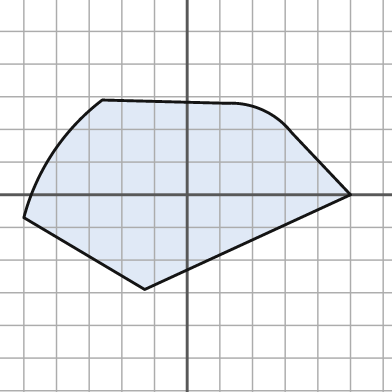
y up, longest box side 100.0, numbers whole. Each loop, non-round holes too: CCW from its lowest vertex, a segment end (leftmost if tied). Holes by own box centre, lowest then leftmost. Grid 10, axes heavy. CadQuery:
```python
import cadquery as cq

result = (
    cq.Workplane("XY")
    .moveTo(-13.0, -29.0)
    .lineTo(50.0, 0.0)
    .lineTo(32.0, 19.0)
    .threePointArc((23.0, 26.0), (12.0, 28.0))
    .lineTo(-26.0, 29.0)
    .threePointArc((-41.0, 13.0), (-50.0, -7.0))
    .close()
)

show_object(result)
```